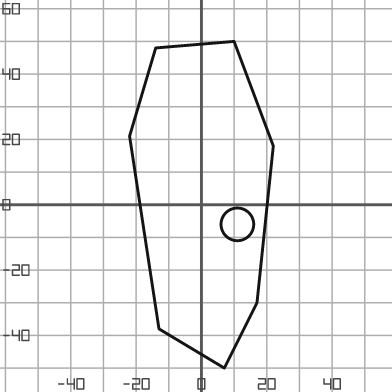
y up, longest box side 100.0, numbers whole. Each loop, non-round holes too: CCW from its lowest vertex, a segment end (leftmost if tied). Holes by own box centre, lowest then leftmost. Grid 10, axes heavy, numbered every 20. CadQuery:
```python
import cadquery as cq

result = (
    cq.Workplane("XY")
    .moveTo(7.0, -50.0)
    .lineTo(17.0, -30.0)
    .lineTo(22.0, 18.0)
    .lineTo(10.0, 50.0)
    .lineTo(-14.0, 48.0)
    .lineTo(-22.0, 21.0)
    .lineTo(-13.0, -38.0)
    .close()
    .moveTo(11.0, -6.0)
    .circle(5.0)
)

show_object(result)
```